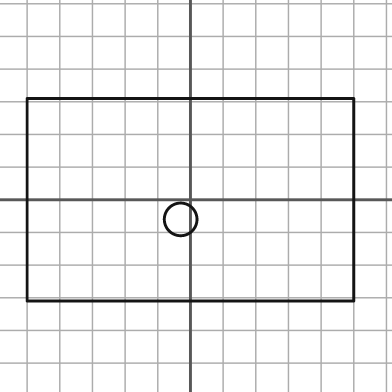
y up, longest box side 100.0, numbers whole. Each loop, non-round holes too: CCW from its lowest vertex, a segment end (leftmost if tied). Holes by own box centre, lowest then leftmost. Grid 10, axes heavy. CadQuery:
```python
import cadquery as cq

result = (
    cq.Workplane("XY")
    .moveTo(-50.0, -31.0)
    .lineTo(50.0, -31.0)
    .lineTo(50.0, 31.0)
    .lineTo(-50.0, 31.0)
    .close()
    .moveTo(-3.0, -6.0)
    .circle(5.0)
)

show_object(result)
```